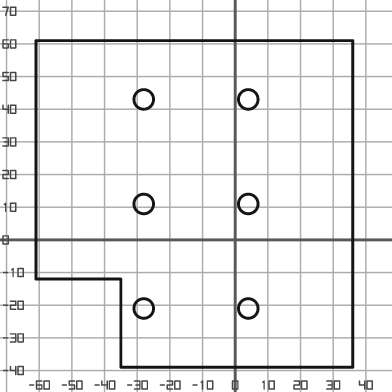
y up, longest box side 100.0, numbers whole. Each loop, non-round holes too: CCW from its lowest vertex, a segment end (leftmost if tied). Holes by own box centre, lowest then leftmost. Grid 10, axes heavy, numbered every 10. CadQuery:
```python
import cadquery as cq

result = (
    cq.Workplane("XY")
    .moveTo(-35.0, -39.0)
    .lineTo(36.0, -39.0)
    .lineTo(36.0, 61.0)
    .lineTo(-61.0, 61.0)
    .lineTo(-61.0, -12.0)
    .lineTo(-35.0, -12.0)
    .close()
    .moveTo(-28.0, -21.0)
    .circle(3.0)
    .moveTo(4.0, -21.0)
    .circle(3.0)
    .moveTo(-28.0, 11.0)
    .circle(3.0)
    .moveTo(4.0, 11.0)
    .circle(3.0)
    .moveTo(-28.0, 43.0)
    .circle(3.0)
    .moveTo(4.0, 43.0)
    .circle(3.0)
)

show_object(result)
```